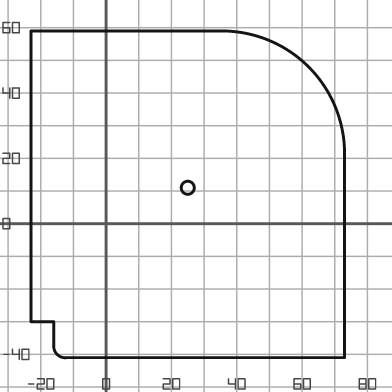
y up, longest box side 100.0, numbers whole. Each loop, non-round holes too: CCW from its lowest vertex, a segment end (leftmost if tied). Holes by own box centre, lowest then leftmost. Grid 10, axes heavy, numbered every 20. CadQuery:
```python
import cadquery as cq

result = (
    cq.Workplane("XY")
    .moveTo(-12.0, -41.0)
    .lineTo(73.0, -41.0)
    .lineTo(73.0, 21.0)
    .threePointArc((62.0, 48.0), (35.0, 59.0))
    .lineTo(-23.0, 59.0)
    .lineTo(-23.0, -30.0)
    .lineTo(-16.0, -30.0)
    .lineTo(-16.0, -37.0)
    .threePointArc((-15.0, -40.0), (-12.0, -41.0))
    .close()
    .moveTo(25.0, 11.0)
    .circle(2.0)
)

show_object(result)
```